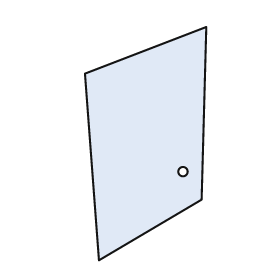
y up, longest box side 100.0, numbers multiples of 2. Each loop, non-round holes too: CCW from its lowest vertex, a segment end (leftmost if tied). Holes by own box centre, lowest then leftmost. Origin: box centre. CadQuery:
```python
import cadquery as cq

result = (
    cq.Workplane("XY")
    .moveTo(-20.0, -50.0)
    .lineTo(24.0, -24.0)
    .lineTo(26.0, 50.0)
    .lineTo(-26.0, 30.0)
    .close()
    .moveTo(16.0, -12.0)
    .circle(2.0)
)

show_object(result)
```